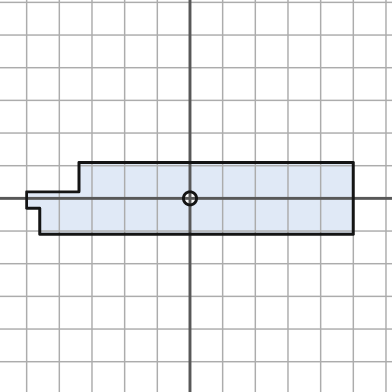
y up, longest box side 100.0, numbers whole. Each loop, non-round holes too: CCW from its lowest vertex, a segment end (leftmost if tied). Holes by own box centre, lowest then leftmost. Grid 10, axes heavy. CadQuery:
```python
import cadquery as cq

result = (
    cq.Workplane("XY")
    .moveTo(-46.0, -11.0)
    .lineTo(50.0, -11.0)
    .lineTo(50.0, 11.0)
    .lineTo(-34.0, 11.0)
    .lineTo(-34.0, 2.0)
    .lineTo(-50.0, 2.0)
    .lineTo(-50.0, -3.0)
    .lineTo(-46.0, -3.0)
    .close()
    .moveTo(0.0, 0.0)
    .circle(2.0)
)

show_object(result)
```